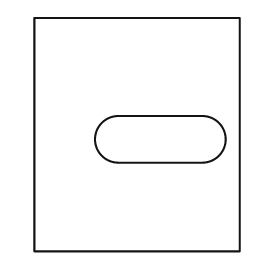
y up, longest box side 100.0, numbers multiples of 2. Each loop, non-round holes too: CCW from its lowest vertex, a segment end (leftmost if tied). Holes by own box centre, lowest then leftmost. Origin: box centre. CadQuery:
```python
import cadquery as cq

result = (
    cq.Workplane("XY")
    .moveTo(-44.0, -50.0)
    .lineTo(44.0, -50.0)
    .lineTo(44.0, 50.0)
    .lineTo(-44.0, 50.0)
    .close()
    .moveTo(-8.0, -12.0)
    .lineTo(28.0, -12.0)
    .threePointArc((38.0, -2.0), (28.0, 8.0))
    .lineTo(-8.0, 8.0)
    .threePointArc((-18.0, -2.0), (-8.0, -12.0))
    .close()
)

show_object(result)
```